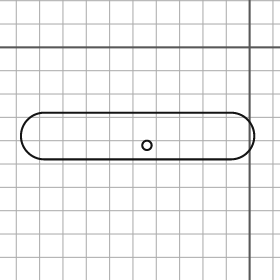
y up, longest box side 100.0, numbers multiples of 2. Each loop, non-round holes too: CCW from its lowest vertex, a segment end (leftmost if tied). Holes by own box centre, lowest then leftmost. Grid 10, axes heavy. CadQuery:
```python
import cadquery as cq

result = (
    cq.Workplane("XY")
    .moveTo(-88.0, -48.0)
    .lineTo(-8.0, -48.0)
    .threePointArc((2.0, -38.0), (-8.0, -28.0))
    .lineTo(-88.0, -28.0)
    .threePointArc((-98.0, -38.0), (-88.0, -48.0))
    .close()
    .moveTo(-44.0, -42.0)
    .circle(2.0)
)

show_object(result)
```